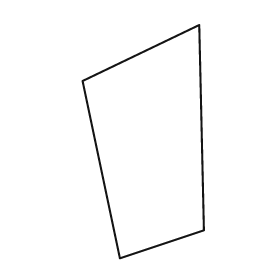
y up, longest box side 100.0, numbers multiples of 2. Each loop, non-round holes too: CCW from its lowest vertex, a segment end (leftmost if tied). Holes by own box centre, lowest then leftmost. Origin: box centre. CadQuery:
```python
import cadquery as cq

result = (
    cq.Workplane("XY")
    .moveTo(-10.0, -50.0)
    .lineTo(26.0, -38.0)
    .lineTo(24.0, 50.0)
    .lineTo(-26.0, 26.0)
    .close()
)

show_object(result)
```